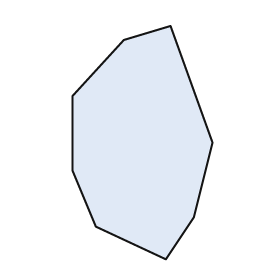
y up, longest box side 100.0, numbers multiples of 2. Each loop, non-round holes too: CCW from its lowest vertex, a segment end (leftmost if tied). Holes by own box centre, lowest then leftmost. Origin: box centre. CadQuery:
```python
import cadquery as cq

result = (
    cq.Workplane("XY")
    .moveTo(10.0, -50.0)
    .lineTo(22.0, -32.0)
    .lineTo(30.0, 0.0)
    .lineTo(12.0, 50.0)
    .lineTo(-8.0, 44.0)
    .lineTo(-30.0, 20.0)
    .lineTo(-30.0, -12.0)
    .lineTo(-20.0, -36.0)
    .close()
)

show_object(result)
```